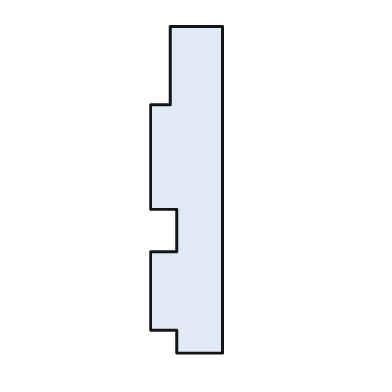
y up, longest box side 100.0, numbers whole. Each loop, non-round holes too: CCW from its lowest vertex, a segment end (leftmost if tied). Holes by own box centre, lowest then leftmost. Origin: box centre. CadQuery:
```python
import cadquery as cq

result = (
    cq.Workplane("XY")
    .moveTo(-3.0, -50.0)
    .lineTo(11.0, -50.0)
    .lineTo(11.0, 50.0)
    .lineTo(-5.0, 50.0)
    .lineTo(-5.0, 26.0)
    .lineTo(-11.0, 26.0)
    .lineTo(-11.0, -6.0)
    .lineTo(-3.0, -6.0)
    .lineTo(-3.0, -19.0)
    .lineTo(-11.0, -19.0)
    .lineTo(-11.0, -43.0)
    .lineTo(-3.0, -43.0)
    .close()
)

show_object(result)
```